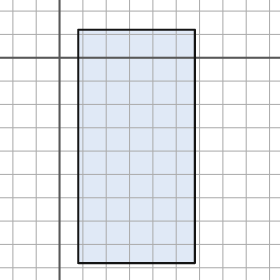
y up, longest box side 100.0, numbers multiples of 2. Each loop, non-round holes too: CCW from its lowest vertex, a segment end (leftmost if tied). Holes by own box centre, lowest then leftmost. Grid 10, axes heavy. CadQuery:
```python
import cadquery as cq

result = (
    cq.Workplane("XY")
    .moveTo(8.0, -88.0)
    .lineTo(58.0, -88.0)
    .lineTo(58.0, 12.0)
    .lineTo(8.0, 12.0)
    .close()
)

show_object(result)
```